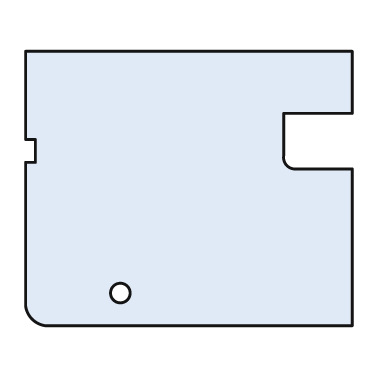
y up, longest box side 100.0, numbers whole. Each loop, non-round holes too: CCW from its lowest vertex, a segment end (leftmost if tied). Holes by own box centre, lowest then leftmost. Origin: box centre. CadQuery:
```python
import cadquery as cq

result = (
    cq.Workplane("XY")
    .moveTo(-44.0, -42.0)
    .lineTo(50.0, -42.0)
    .lineTo(50.0, 6.0)
    .lineTo(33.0, 6.0)
    .threePointArc((30.0, 7.0), (29.0, 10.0))
    .lineTo(29.0, 23.0)
    .lineTo(50.0, 23.0)
    .lineTo(50.0, 42.0)
    .lineTo(-50.0, 42.0)
    .lineTo(-50.0, 15.0)
    .lineTo(-47.0, 15.0)
    .lineTo(-47.0, 8.0)
    .lineTo(-50.0, 8.0)
    .lineTo(-50.0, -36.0)
    .threePointArc((-48.0, -40.0), (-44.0, -42.0))
    .close()
    .moveTo(-21.0, -32.0)
    .circle(3.0)
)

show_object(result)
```